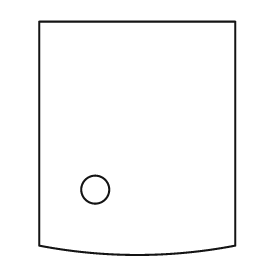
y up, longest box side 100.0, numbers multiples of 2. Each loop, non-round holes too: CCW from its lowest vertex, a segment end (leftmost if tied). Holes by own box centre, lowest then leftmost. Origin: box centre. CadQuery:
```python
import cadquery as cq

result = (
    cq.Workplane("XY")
    .moveTo(-42.0, -46.0)
    .threePointArc((0.0, -50.0), (42.0, -46.0))
    .lineTo(42.0, 50.0)
    .lineTo(-42.0, 50.0)
    .close()
    .moveTo(-18.0, -22.0)
    .circle(6.0)
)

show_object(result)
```